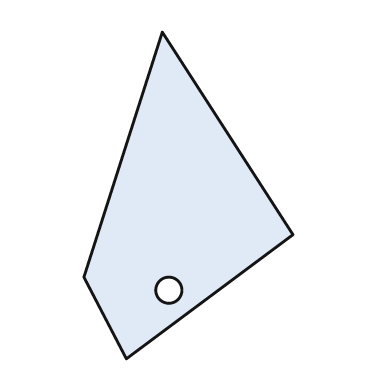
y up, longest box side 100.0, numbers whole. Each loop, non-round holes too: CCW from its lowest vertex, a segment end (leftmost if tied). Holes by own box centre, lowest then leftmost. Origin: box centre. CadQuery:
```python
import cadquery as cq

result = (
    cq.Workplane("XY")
    .moveTo(-19.0, -50.0)
    .lineTo(32.0, -12.0)
    .lineTo(-8.0, 50.0)
    .lineTo(-32.0, -25.0)
    .close()
    .moveTo(-6.0, -29.0)
    .circle(4.0)
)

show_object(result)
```